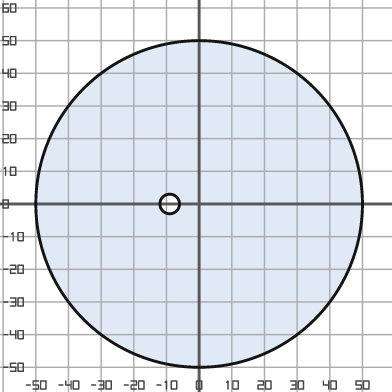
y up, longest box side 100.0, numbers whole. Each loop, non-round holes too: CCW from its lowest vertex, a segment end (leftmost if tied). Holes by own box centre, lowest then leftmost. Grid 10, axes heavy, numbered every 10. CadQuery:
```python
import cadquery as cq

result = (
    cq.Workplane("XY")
    .moveTo(0.0, 0.0)
    .circle(50.0)
    .moveTo(-9.0, 0.0)
    .circle(3.0)
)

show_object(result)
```